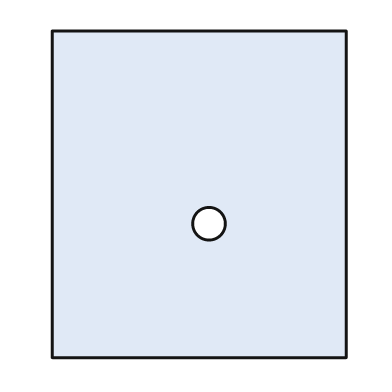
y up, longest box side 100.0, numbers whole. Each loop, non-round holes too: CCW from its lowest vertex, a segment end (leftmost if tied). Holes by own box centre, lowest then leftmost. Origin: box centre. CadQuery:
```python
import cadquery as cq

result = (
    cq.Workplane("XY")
    .moveTo(-45.0, -50.0)
    .lineTo(45.0, -50.0)
    .lineTo(45.0, 50.0)
    .lineTo(-45.0, 50.0)
    .close()
    .moveTo(3.0, -9.0)
    .circle(5.0)
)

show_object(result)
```